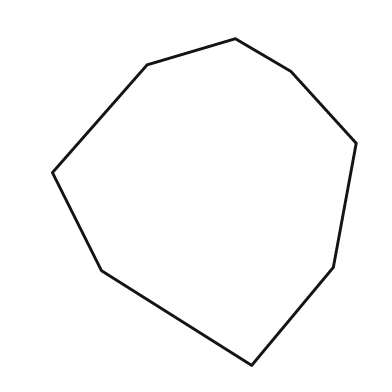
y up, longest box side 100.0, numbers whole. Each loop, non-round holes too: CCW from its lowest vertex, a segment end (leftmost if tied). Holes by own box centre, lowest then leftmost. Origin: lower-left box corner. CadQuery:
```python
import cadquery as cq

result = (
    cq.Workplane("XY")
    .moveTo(61.0, 0.0)
    .lineTo(86.0, 30.0)
    .lineTo(93.0, 68.0)
    .lineTo(73.0, 90.0)
    .lineTo(56.0, 100.0)
    .lineTo(29.0, 92.0)
    .lineTo(0.0, 59.0)
    .lineTo(15.0, 29.0)
    .close()
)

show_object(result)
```